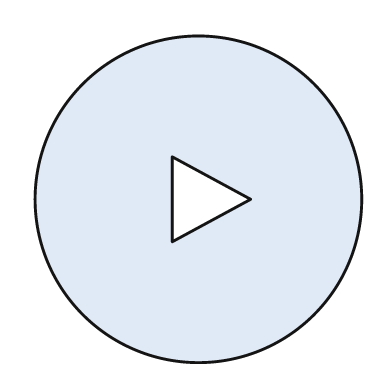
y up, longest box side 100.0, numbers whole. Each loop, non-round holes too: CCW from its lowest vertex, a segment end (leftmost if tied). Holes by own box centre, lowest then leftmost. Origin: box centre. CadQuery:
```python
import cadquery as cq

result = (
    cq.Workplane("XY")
    .moveTo(0.0, 0.0)
    .circle(50.0)
    .moveTo(-8.0, -13.0)
    .lineTo(16.0, 0.0)
    .lineTo(-8.0, 13.0)
    .close()
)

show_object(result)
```